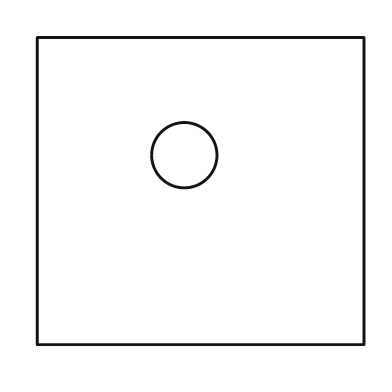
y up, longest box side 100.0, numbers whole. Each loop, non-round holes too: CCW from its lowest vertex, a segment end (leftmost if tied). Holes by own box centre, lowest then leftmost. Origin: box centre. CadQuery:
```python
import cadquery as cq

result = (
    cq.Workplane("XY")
    .moveTo(-50.0, -47.0)
    .lineTo(50.0, -47.0)
    .lineTo(50.0, 47.0)
    .lineTo(-50.0, 47.0)
    .close()
    .moveTo(-5.0, 11.0)
    .circle(10.0)
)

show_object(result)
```